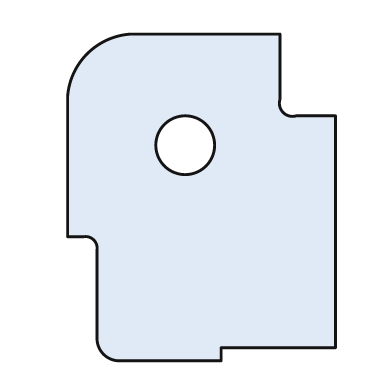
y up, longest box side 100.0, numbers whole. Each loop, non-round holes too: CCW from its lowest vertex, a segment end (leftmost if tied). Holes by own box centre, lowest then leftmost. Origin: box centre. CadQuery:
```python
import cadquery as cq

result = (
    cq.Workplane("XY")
    .moveTo(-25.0, -50.0)
    .lineTo(6.0, -50.0)
    .lineTo(6.0, -46.0)
    .lineTo(41.0, -46.0)
    .lineTo(41.0, 25.0)
    .lineTo(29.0, 25.0)
    .threePointArc((25.0, 26.0), (24.0, 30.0))
    .lineTo(24.0, 50.0)
    .lineTo(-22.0, 50.0)
    .threePointArc((-35.0, 44.0), (-41.0, 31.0))
    .lineTo(-41.0, -12.0)
    .lineTo(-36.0, -12.0)
    .threePointArc((-33.0, -13.0), (-32.0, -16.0))
    .lineTo(-32.0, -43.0)
    .threePointArc((-30.0, -48.0), (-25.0, -50.0))
    .close()
    .moveTo(-5.0, 16.0)
    .circle(9.0)
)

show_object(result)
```